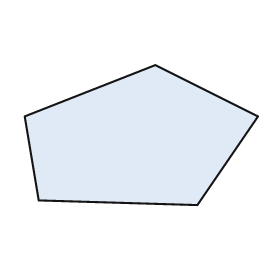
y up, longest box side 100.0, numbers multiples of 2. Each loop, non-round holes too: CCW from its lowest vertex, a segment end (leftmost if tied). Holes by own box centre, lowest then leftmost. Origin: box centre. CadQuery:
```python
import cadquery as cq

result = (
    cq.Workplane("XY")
    .moveTo(24.0, -30.0)
    .lineTo(50.0, 8.0)
    .lineTo(6.0, 30.0)
    .lineTo(-50.0, 8.0)
    .lineTo(-44.0, -28.0)
    .close()
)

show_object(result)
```